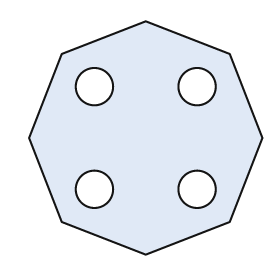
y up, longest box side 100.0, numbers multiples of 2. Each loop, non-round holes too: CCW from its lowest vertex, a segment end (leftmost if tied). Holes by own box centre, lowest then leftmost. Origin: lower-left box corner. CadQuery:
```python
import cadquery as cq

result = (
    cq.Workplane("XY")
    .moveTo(50.0, 0.0)
    .lineTo(86.0, 14.0)
    .lineTo(100.0, 50.0)
    .lineTo(86.0, 86.0)
    .lineTo(50.0, 100.0)
    .lineTo(14.0, 86.0)
    .lineTo(0.0, 50.0)
    .lineTo(14.0, 14.0)
    .close()
    .moveTo(28.0, 28.0)
    .circle(8.0)
    .moveTo(72.0, 28.0)
    .circle(8.0)
    .moveTo(28.0, 72.0)
    .circle(8.0)
    .moveTo(72.0, 72.0)
    .circle(8.0)
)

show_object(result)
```